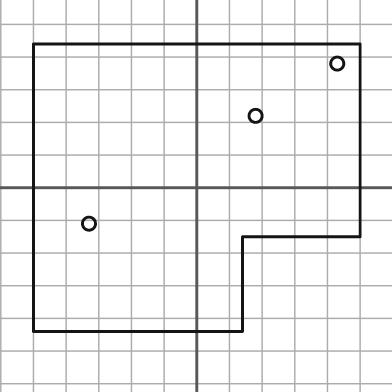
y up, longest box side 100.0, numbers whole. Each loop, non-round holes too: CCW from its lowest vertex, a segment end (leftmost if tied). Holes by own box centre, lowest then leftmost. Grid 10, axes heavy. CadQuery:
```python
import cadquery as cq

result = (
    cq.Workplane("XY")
    .moveTo(-50.0, -44.0)
    .lineTo(14.0, -44.0)
    .lineTo(14.0, -15.0)
    .lineTo(50.0, -15.0)
    .lineTo(50.0, 44.0)
    .lineTo(-50.0, 44.0)
    .close()
    .moveTo(-33.0, -11.0)
    .circle(2.0)
    .moveTo(18.0, 22.0)
    .circle(2.0)
    .moveTo(43.0, 38.0)
    .circle(2.0)
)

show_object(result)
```